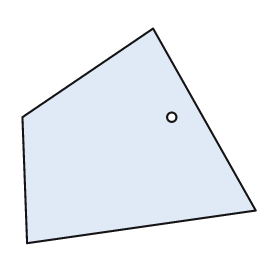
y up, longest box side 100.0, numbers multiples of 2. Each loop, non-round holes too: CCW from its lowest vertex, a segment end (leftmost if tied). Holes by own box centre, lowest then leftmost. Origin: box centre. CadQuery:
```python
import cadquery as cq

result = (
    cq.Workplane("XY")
    .moveTo(-48.0, -46.0)
    .lineTo(50.0, -32.0)
    .lineTo(6.0, 46.0)
    .lineTo(-50.0, 8.0)
    .close()
    .moveTo(14.0, 8.0)
    .circle(2.0)
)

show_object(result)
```